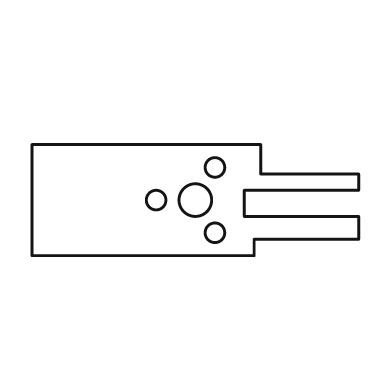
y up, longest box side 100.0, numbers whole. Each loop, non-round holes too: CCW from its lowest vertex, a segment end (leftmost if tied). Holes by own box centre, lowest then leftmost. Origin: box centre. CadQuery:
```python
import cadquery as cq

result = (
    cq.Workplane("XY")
    .moveTo(-50.0, -17.0)
    .lineTo(18.0, -17.0)
    .lineTo(18.0, -12.0)
    .lineTo(50.0, -12.0)
    .lineTo(50.0, -5.0)
    .lineTo(15.0, -5.0)
    .lineTo(15.0, 3.0)
    .lineTo(50.0, 3.0)
    .lineTo(50.0, 8.0)
    .lineTo(20.0, 8.0)
    .lineTo(20.0, 17.0)
    .lineTo(-50.0, 17.0)
    .close()
    .moveTo(6.0, -10.0)
    .circle(3.0)
    .moveTo(-12.0, 0.0)
    .circle(3.0)
    .moveTo(0.0, 0.0)
    .circle(5.0)
    .moveTo(6.0, 10.0)
    .circle(3.0)
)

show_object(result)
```